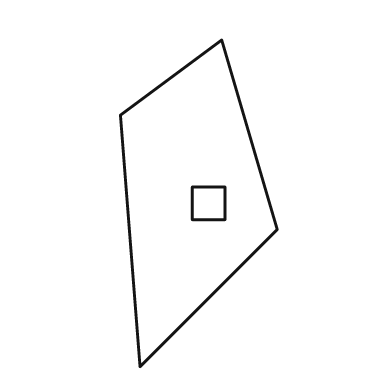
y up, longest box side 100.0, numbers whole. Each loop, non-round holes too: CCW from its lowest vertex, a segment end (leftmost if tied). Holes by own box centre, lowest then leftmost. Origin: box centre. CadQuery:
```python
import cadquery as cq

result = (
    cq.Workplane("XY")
    .moveTo(-18.0, -50.0)
    .lineTo(24.0, -8.0)
    .lineTo(7.0, 50.0)
    .lineTo(-24.0, 27.0)
    .close()
    .moveTo(-2.0, -5.0)
    .lineTo(8.0, -5.0)
    .lineTo(8.0, 5.0)
    .lineTo(-2.0, 5.0)
    .close()
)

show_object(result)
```